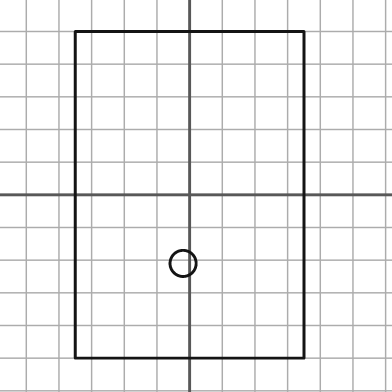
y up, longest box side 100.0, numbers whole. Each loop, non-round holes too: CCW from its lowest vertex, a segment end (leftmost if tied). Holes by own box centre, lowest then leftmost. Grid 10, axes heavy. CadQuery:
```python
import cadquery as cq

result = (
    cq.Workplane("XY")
    .moveTo(-35.0, -50.0)
    .lineTo(35.0, -50.0)
    .lineTo(35.0, 50.0)
    .lineTo(-35.0, 50.0)
    .close()
    .moveTo(-2.0, -21.0)
    .circle(4.0)
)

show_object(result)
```